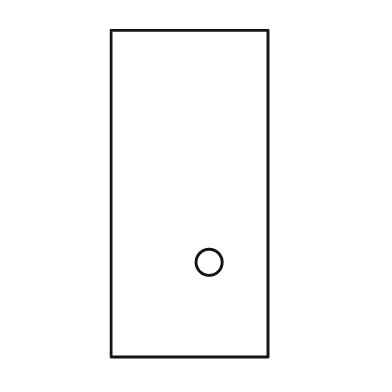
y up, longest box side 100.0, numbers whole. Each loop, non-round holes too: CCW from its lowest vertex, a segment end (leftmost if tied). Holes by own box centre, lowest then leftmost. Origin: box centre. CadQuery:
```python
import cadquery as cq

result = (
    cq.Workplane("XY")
    .moveTo(-24.0, -50.0)
    .lineTo(24.0, -50.0)
    .lineTo(24.0, 50.0)
    .lineTo(-24.0, 50.0)
    .close()
    .moveTo(6.0, -21.0)
    .circle(4.0)
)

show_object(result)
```